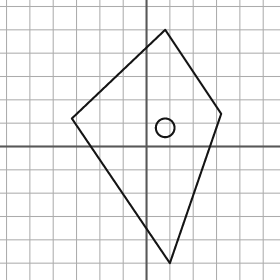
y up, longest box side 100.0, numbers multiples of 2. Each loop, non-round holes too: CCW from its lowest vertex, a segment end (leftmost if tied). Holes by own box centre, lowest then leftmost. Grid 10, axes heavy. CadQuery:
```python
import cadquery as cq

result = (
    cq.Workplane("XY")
    .moveTo(10.0, -50.0)
    .lineTo(32.0, 14.0)
    .lineTo(8.0, 50.0)
    .lineTo(-32.0, 12.0)
    .close()
    .moveTo(8.0, 8.0)
    .circle(4.0)
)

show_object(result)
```